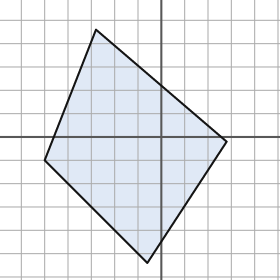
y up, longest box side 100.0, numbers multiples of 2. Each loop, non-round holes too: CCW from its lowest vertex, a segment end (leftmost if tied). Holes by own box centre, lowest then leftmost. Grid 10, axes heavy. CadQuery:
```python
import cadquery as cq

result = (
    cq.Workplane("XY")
    .moveTo(-6.0, -54.0)
    .lineTo(28.0, -2.0)
    .lineTo(-28.0, 46.0)
    .lineTo(-50.0, -10.0)
    .close()
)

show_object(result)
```